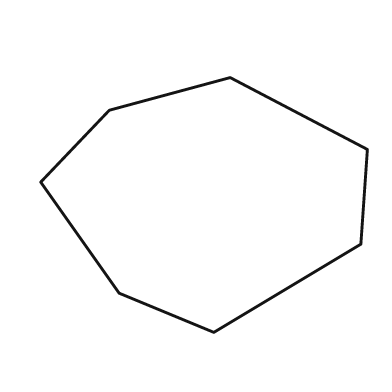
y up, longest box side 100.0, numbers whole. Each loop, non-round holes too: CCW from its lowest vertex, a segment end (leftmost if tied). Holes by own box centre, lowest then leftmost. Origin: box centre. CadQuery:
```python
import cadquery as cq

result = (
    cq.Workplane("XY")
    .moveTo(3.0, -39.0)
    .lineTo(48.0, -12.0)
    .lineTo(50.0, 17.0)
    .lineTo(8.0, 39.0)
    .lineTo(-29.0, 29.0)
    .lineTo(-50.0, 7.0)
    .lineTo(-26.0, -27.0)
    .close()
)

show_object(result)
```